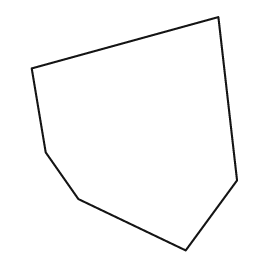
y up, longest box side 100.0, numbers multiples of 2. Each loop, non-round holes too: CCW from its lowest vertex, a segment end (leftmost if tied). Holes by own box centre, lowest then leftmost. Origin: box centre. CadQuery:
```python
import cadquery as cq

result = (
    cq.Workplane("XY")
    .moveTo(22.0, -50.0)
    .lineTo(44.0, -20.0)
    .lineTo(36.0, 50.0)
    .lineTo(-44.0, 28.0)
    .lineTo(-38.0, -8.0)
    .lineTo(-24.0, -28.0)
    .close()
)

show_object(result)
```